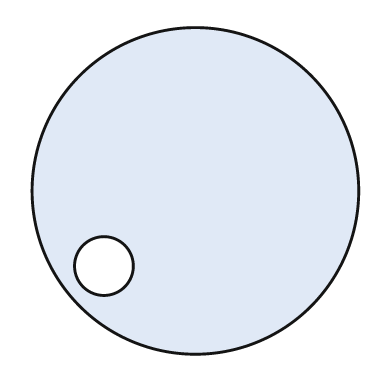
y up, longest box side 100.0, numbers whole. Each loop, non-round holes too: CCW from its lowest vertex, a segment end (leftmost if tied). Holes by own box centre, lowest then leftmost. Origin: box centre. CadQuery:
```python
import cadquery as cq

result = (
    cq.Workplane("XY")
    .moveTo(0.0, 0.0)
    .circle(50.0)
    .moveTo(-28.0, -23.0)
    .circle(9.0)
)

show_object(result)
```